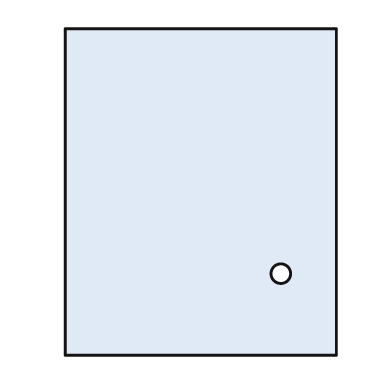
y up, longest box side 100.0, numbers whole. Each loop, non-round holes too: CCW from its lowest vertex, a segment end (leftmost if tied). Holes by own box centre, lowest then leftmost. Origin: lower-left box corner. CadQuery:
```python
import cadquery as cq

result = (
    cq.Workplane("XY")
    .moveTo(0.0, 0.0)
    .lineTo(83.0, 0.0)
    .lineTo(83.0, 100.0)
    .lineTo(0.0, 100.0)
    .close()
    .moveTo(66.0, 25.0)
    .circle(3.0)
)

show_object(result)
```